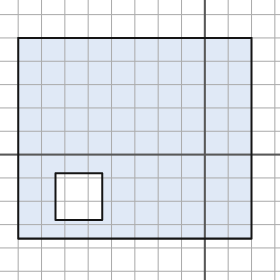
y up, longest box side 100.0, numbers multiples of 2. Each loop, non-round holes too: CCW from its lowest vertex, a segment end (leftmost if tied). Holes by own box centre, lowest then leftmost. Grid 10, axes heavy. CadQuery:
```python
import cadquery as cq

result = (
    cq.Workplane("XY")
    .moveTo(-80.0, -36.0)
    .lineTo(20.0, -36.0)
    .lineTo(20.0, 50.0)
    .lineTo(-80.0, 50.0)
    .close()
    .moveTo(-64.0, -28.0)
    .lineTo(-44.0, -28.0)
    .lineTo(-44.0, -8.0)
    .lineTo(-64.0, -8.0)
    .close()
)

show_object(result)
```